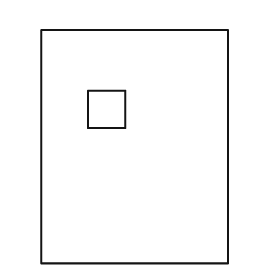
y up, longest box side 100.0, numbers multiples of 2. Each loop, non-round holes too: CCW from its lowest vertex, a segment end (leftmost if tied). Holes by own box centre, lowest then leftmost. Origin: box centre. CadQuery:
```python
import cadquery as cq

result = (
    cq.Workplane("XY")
    .moveTo(-40.0, -50.0)
    .lineTo(40.0, -50.0)
    .lineTo(40.0, 50.0)
    .lineTo(-40.0, 50.0)
    .close()
    .moveTo(-20.0, 8.0)
    .lineTo(-4.0, 8.0)
    .lineTo(-4.0, 24.0)
    .lineTo(-20.0, 24.0)
    .close()
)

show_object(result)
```